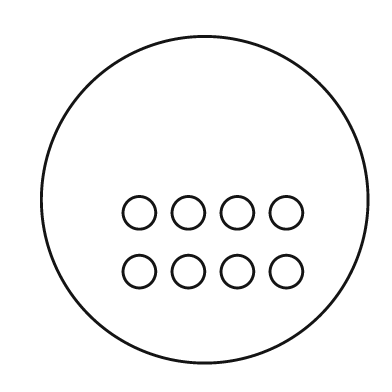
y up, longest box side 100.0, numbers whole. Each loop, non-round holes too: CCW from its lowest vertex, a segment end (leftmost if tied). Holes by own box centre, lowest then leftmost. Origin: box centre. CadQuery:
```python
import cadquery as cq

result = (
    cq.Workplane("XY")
    .moveTo(0.0, 0.0)
    .circle(50.0)
    .moveTo(-20.0, -22.0)
    .circle(5.0)
    .moveTo(-5.0, -22.0)
    .circle(5.0)
    .moveTo(10.0, -22.0)
    .circle(5.0)
    .moveTo(25.0, -22.0)
    .circle(5.0)
    .moveTo(-20.0, -4.0)
    .circle(5.0)
    .moveTo(-5.0, -4.0)
    .circle(5.0)
    .moveTo(10.0, -4.0)
    .circle(5.0)
    .moveTo(25.0, -4.0)
    .circle(5.0)
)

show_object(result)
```